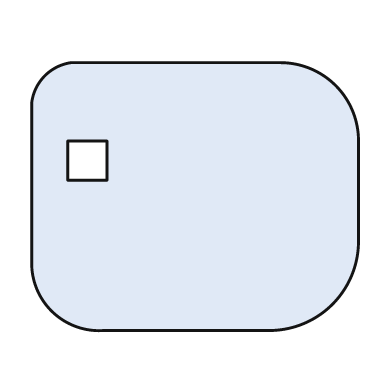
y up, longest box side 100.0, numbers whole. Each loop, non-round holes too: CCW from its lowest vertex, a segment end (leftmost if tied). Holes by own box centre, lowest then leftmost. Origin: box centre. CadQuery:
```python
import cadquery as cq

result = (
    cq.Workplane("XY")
    .moveTo(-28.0, -41.0)
    .lineTo(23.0, -41.0)
    .threePointArc((42.0, -33.0), (50.0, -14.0))
    .lineTo(50.0, 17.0)
    .threePointArc((43.0, 34.0), (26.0, 41.0))
    .lineTo(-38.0, 41.0)
    .threePointArc((-46.0, 37.0), (-50.0, 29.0))
    .lineTo(-50.0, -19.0)
    .threePointArc((-44.0, -35.0), (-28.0, -41.0))
    .close()
    .moveTo(-39.0, 5.0)
    .lineTo(-27.0, 5.0)
    .lineTo(-27.0, 17.0)
    .lineTo(-39.0, 17.0)
    .close()
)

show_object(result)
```